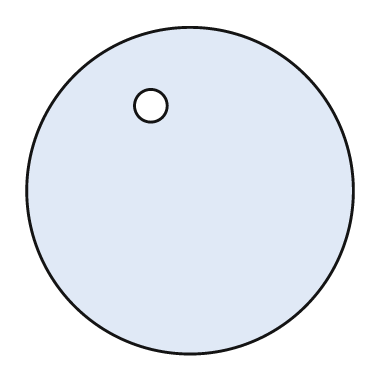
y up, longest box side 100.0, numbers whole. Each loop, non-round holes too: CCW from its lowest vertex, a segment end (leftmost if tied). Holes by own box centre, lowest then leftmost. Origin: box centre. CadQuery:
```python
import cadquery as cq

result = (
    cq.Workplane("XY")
    .moveTo(0.0, 0.0)
    .circle(50.0)
    .moveTo(-12.0, 26.0)
    .circle(5.0)
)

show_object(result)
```